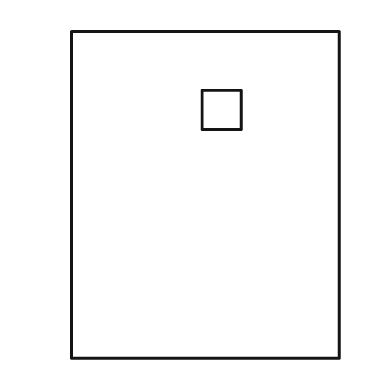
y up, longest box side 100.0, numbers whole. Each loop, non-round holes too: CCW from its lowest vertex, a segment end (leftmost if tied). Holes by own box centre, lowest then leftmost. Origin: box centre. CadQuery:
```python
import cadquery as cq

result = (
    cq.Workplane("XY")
    .moveTo(-41.0, -50.0)
    .lineTo(41.0, -50.0)
    .lineTo(41.0, 50.0)
    .lineTo(-41.0, 50.0)
    .close()
    .moveTo(-1.0, 20.0)
    .lineTo(11.0, 20.0)
    .lineTo(11.0, 32.0)
    .lineTo(-1.0, 32.0)
    .close()
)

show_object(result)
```